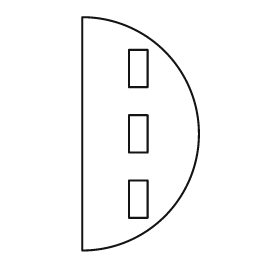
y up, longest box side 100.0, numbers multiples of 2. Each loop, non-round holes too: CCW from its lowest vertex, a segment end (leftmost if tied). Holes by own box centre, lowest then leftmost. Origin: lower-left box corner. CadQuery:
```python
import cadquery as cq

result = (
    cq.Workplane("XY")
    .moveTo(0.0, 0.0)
    .threePointArc((50.0, 50.0), (0.0, 100.0))
    .close()
    .moveTo(20.0, 14.0)
    .lineTo(28.0, 14.0)
    .lineTo(28.0, 30.0)
    .lineTo(20.0, 30.0)
    .close()
    .moveTo(20.0, 42.0)
    .lineTo(28.0, 42.0)
    .lineTo(28.0, 58.0)
    .lineTo(20.0, 58.0)
    .close()
    .moveTo(20.0, 70.0)
    .lineTo(28.0, 70.0)
    .lineTo(28.0, 86.0)
    .lineTo(20.0, 86.0)
    .close()
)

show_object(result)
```